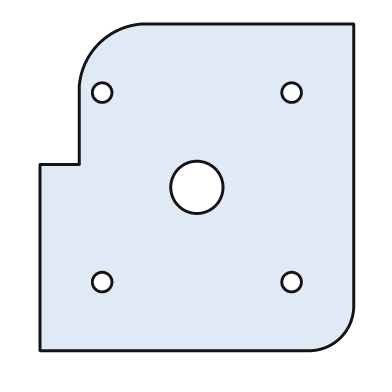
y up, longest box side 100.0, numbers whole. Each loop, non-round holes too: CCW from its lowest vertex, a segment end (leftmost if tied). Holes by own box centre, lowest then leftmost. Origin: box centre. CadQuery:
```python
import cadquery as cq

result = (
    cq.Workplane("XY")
    .moveTo(-48.0, -50.0)
    .lineTo(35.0, -50.0)
    .threePointArc((44.0, -46.0), (48.0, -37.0))
    .lineTo(48.0, 50.0)
    .lineTo(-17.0, 50.0)
    .threePointArc((-30.0, 44.0), (-36.0, 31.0))
    .lineTo(-36.0, 7.0)
    .lineTo(-48.0, 7.0)
    .close()
    .moveTo(-29.0, -29.0)
    .circle(3.0)
    .moveTo(29.0, -29.0)
    .circle(3.0)
    .moveTo(0.0, 0.0)
    .circle(8.0)
    .moveTo(-29.0, 29.0)
    .circle(3.0)
    .moveTo(29.0, 29.0)
    .circle(3.0)
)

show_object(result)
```